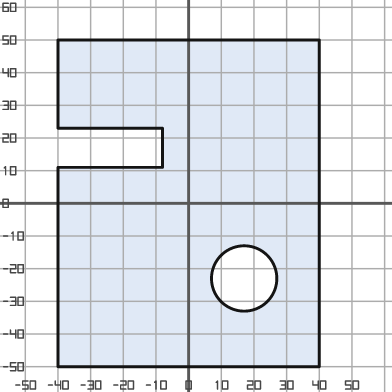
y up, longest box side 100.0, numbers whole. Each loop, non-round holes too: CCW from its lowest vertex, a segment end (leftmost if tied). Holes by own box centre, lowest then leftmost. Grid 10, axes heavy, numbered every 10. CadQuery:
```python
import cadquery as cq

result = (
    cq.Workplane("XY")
    .moveTo(-40.0, -50.0)
    .lineTo(40.0, -50.0)
    .lineTo(40.0, 50.0)
    .lineTo(-40.0, 50.0)
    .lineTo(-40.0, 23.0)
    .lineTo(-8.0, 23.0)
    .lineTo(-8.0, 11.0)
    .lineTo(-40.0, 11.0)
    .close()
    .moveTo(17.0, -23.0)
    .circle(10.0)
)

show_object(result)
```